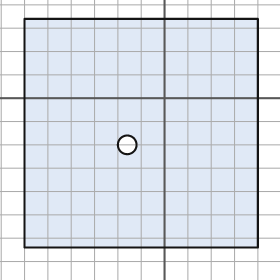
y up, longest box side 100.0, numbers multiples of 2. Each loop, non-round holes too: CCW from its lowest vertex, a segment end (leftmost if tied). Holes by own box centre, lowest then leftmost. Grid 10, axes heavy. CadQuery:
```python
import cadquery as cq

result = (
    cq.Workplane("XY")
    .moveTo(-60.0, -64.0)
    .lineTo(40.0, -64.0)
    .lineTo(40.0, 34.0)
    .lineTo(-60.0, 34.0)
    .close()
    .moveTo(-16.0, -20.0)
    .circle(4.0)
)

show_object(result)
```